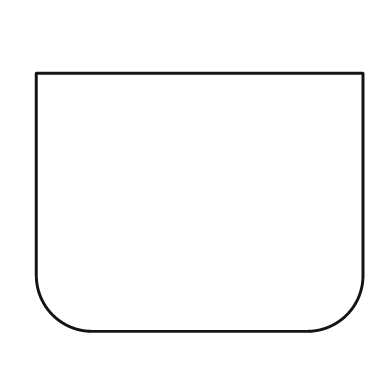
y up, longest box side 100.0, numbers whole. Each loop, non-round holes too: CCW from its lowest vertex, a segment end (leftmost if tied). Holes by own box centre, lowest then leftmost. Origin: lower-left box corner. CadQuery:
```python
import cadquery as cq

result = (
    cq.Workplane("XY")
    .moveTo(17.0, 0.0)
    .lineTo(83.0, 0.0)
    .threePointArc((95.0, 5.0), (100.0, 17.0))
    .lineTo(100.0, 79.0)
    .lineTo(0.0, 79.0)
    .lineTo(0.0, 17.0)
    .threePointArc((5.0, 5.0), (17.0, 0.0))
    .close()
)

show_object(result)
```